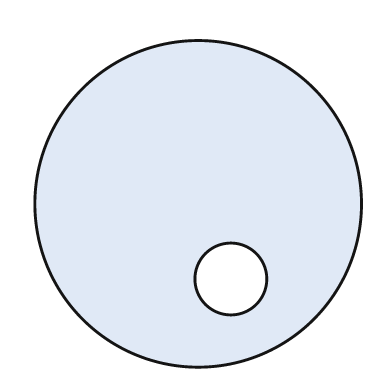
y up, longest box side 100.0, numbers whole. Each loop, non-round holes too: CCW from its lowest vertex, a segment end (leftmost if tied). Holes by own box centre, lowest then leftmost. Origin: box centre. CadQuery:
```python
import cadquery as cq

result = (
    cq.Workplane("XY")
    .moveTo(0.0, 0.0)
    .circle(50.0)
    .moveTo(10.0, -23.0)
    .circle(11.0)
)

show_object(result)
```